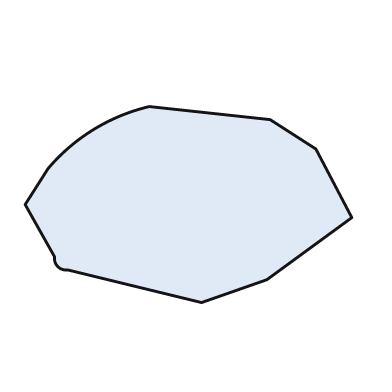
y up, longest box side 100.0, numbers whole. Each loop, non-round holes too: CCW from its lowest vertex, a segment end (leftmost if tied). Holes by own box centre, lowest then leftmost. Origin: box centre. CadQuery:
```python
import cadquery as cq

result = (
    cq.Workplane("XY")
    .moveTo(4.0, -30.0)
    .lineTo(24.0, -23.0)
    .lineTo(50.0, -4.0)
    .lineTo(39.0, 17.0)
    .lineTo(25.0, 26.0)
    .lineTo(-12.0, 30.0)
    .threePointArc((-29.0, 23.0), (-43.0, 11.0))
    .lineTo(-50.0, 0.0)
    .lineTo(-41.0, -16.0)
    .threePointArc((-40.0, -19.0), (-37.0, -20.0))
    .close()
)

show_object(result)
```